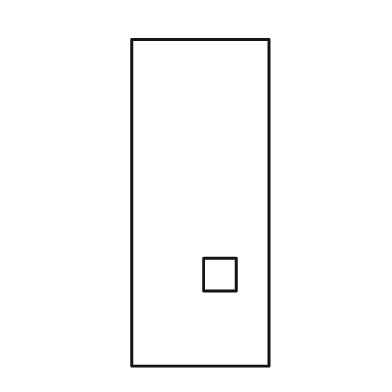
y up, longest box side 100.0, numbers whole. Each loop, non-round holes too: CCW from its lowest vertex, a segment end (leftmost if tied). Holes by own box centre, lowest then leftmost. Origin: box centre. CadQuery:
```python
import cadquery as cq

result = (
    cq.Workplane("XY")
    .moveTo(-21.0, -50.0)
    .lineTo(21.0, -50.0)
    .lineTo(21.0, 50.0)
    .lineTo(-21.0, 50.0)
    .close()
    .moveTo(1.0, -27.0)
    .lineTo(11.0, -27.0)
    .lineTo(11.0, -17.0)
    .lineTo(1.0, -17.0)
    .close()
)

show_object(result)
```